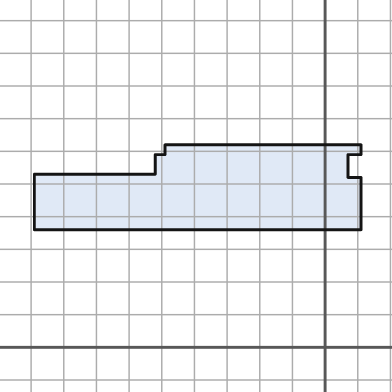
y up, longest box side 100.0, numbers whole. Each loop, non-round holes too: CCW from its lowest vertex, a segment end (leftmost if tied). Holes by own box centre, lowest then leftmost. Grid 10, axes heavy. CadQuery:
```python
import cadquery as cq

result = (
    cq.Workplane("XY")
    .moveTo(-89.0, 36.0)
    .lineTo(11.0, 36.0)
    .lineTo(11.0, 52.0)
    .lineTo(7.0, 52.0)
    .lineTo(7.0, 59.0)
    .lineTo(11.0, 59.0)
    .lineTo(11.0, 62.0)
    .lineTo(-49.0, 62.0)
    .lineTo(-49.0, 59.0)
    .lineTo(-52.0, 59.0)
    .lineTo(-52.0, 53.0)
    .lineTo(-89.0, 53.0)
    .close()
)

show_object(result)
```